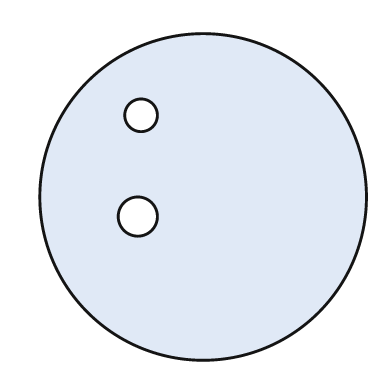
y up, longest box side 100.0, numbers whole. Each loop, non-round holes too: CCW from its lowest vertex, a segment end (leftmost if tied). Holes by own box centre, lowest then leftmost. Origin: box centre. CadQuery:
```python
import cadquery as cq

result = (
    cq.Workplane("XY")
    .moveTo(0.0, 0.0)
    .circle(50.0)
    .moveTo(-20.0, -6.0)
    .circle(6.0)
    .moveTo(-19.0, 25.0)
    .circle(5.0)
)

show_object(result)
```